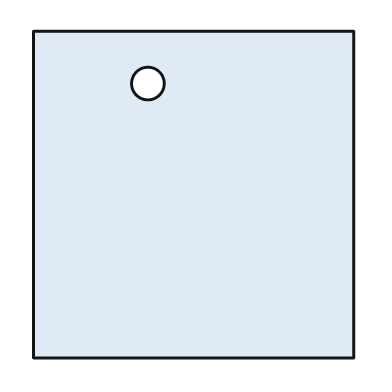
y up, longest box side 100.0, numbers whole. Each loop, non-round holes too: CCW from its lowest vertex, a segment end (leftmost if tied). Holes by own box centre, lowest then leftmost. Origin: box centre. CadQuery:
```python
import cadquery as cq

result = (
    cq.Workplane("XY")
    .moveTo(-49.0, -50.0)
    .lineTo(49.0, -50.0)
    .lineTo(49.0, 50.0)
    .lineTo(-49.0, 50.0)
    .close()
    .moveTo(-14.0, 34.0)
    .circle(5.0)
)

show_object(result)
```